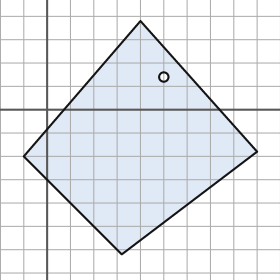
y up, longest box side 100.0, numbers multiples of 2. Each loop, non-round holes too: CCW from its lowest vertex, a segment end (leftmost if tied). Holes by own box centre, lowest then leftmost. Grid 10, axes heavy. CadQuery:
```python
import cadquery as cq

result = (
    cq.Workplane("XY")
    .moveTo(32.0, -62.0)
    .lineTo(90.0, -18.0)
    .lineTo(40.0, 38.0)
    .lineTo(-10.0, -20.0)
    .close()
    .moveTo(50.0, 14.0)
    .circle(2.0)
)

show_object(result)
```